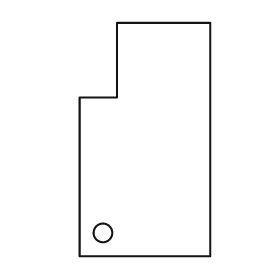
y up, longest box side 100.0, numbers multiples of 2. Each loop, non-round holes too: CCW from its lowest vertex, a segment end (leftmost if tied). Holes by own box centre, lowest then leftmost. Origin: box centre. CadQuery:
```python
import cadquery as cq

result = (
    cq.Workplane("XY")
    .moveTo(-28.0, -50.0)
    .lineTo(28.0, -50.0)
    .lineTo(28.0, 50.0)
    .lineTo(-12.0, 50.0)
    .lineTo(-12.0, 18.0)
    .lineTo(-28.0, 18.0)
    .close()
    .moveTo(-18.0, -40.0)
    .circle(4.0)
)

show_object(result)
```